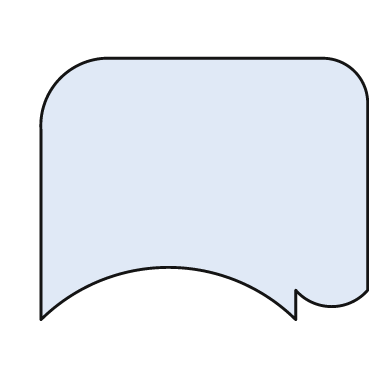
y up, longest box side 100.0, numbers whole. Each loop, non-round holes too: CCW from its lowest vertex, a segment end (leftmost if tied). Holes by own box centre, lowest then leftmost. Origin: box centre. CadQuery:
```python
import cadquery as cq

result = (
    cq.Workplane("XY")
    .moveTo(-50.0, -40.0)
    .threePointArc((-11.0, -24.0), (28.0, -40.0))
    .lineTo(28.0, -31.0)
    .threePointArc((39.0, -36.0), (50.0, -31.0))
    .lineTo(50.0, 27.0)
    .threePointArc((46.0, 36.0), (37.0, 40.0))
    .lineTo(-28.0, 40.0)
    .threePointArc((-44.0, 34.0), (-50.0, 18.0))
    .close()
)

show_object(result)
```